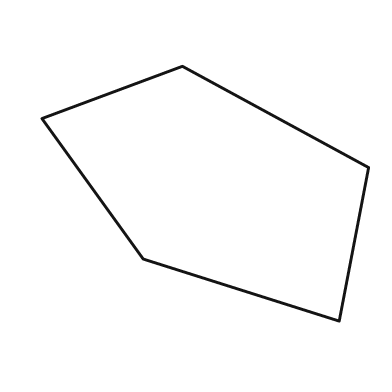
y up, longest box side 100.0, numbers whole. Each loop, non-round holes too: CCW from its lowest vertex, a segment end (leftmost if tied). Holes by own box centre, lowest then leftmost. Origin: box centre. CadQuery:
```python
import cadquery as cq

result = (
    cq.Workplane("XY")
    .moveTo(41.0, -39.0)
    .lineTo(50.0, 8.0)
    .lineTo(-7.0, 39.0)
    .lineTo(-50.0, 23.0)
    .lineTo(-19.0, -20.0)
    .close()
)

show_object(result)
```